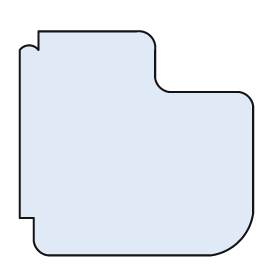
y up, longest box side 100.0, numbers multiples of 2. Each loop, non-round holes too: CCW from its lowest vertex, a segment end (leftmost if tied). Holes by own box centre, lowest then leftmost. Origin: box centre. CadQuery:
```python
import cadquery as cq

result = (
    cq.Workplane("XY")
    .moveTo(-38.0, -48.0)
    .lineTo(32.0, -48.0)
    .threePointArc((44.0, -42.0), (50.0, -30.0))
    .lineTo(50.0, 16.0)
    .threePointArc((48.0, 20.0), (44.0, 22.0))
    .lineTo(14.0, 22.0)
    .threePointArc((10.0, 24.0), (8.0, 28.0))
    .lineTo(8.0, 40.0)
    .threePointArc((6.0, 46.0), (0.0, 48.0))
    .lineTo(-42.0, 48.0)
    .lineTo(-42.0, 40.0)
    .threePointArc((-46.0, 42.0), (-50.0, 40.0))
    .lineTo(-50.0, -32.0)
    .lineTo(-44.0, -32.0)
    .lineTo(-44.0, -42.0)
    .threePointArc((-42.0, -46.0), (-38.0, -48.0))
    .close()
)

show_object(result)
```